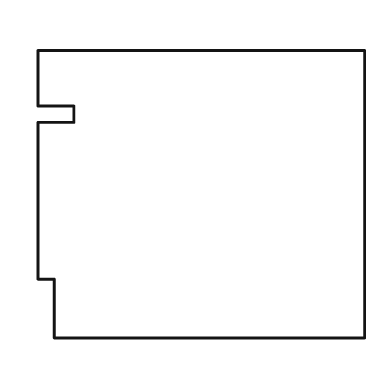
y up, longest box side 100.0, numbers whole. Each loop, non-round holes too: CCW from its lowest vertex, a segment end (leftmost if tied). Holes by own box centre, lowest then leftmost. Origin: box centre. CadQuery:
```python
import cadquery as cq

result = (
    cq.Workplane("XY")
    .moveTo(-45.0, -44.0)
    .lineTo(50.0, -44.0)
    .lineTo(50.0, 44.0)
    .lineTo(-50.0, 44.0)
    .lineTo(-50.0, 27.0)
    .lineTo(-39.0, 27.0)
    .lineTo(-39.0, 22.0)
    .lineTo(-50.0, 22.0)
    .lineTo(-50.0, -26.0)
    .lineTo(-45.0, -26.0)
    .close()
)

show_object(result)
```